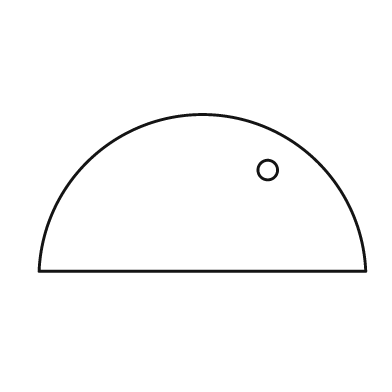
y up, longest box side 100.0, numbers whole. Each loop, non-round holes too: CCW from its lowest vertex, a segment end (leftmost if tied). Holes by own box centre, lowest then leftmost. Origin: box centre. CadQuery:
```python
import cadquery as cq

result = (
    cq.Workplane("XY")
    .moveTo(-50.0, -24.0)
    .lineTo(50.0, -24.0)
    .threePointArc((0.0, 24.0), (-50.0, -24.0))
    .close()
    .moveTo(20.0, 7.0)
    .circle(3.0)
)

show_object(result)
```